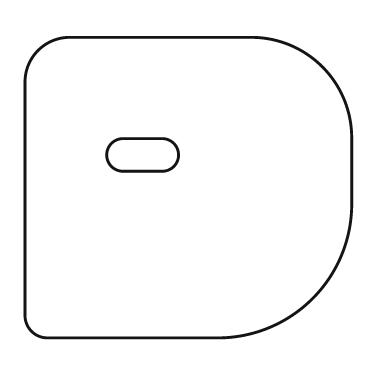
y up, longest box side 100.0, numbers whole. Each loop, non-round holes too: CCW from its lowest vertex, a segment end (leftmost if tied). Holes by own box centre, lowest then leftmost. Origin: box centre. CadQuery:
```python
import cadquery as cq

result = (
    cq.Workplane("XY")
    .moveTo(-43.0, -46.0)
    .lineTo(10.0, -46.0)
    .threePointArc((38.0, -34.0), (50.0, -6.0))
    .lineTo(50.0, 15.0)
    .threePointArc((41.0, 37.0), (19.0, 46.0))
    .lineTo(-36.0, 46.0)
    .threePointArc((-46.0, 42.0), (-50.0, 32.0))
    .lineTo(-50.0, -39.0)
    .threePointArc((-48.0, -44.0), (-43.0, -46.0))
    .close()
    .moveTo(-20.0, 5.0)
    .lineTo(-8.0, 5.0)
    .threePointArc((-3.0, 10.0), (-8.0, 15.0))
    .lineTo(-20.0, 15.0)
    .threePointArc((-25.0, 10.0), (-20.0, 5.0))
    .close()
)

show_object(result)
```